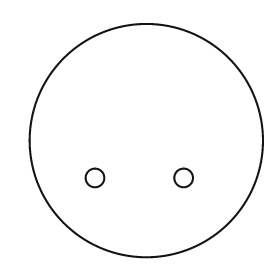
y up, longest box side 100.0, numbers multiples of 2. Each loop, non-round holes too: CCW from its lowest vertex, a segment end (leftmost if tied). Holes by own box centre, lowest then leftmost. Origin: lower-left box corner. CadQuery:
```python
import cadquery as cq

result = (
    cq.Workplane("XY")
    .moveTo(50.0, 50.0)
    .circle(50.0)
    .moveTo(28.0, 34.0)
    .circle(4.0)
    .moveTo(66.0, 34.0)
    .circle(4.0)
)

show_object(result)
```